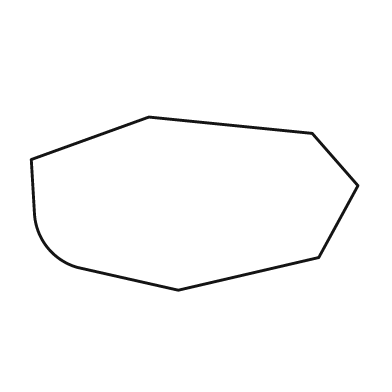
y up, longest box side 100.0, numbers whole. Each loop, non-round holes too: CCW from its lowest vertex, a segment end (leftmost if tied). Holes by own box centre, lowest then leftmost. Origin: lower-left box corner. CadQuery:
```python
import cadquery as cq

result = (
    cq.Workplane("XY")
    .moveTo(45.0, 0.0)
    .lineTo(88.0, 10.0)
    .lineTo(100.0, 32.0)
    .lineTo(86.0, 48.0)
    .lineTo(36.0, 53.0)
    .lineTo(0.0, 40.0)
    .lineTo(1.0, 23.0)
    .threePointArc((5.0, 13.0), (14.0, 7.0))
    .close()
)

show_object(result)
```